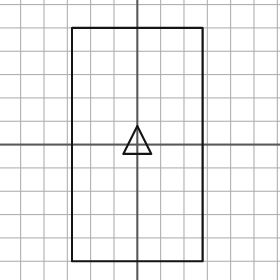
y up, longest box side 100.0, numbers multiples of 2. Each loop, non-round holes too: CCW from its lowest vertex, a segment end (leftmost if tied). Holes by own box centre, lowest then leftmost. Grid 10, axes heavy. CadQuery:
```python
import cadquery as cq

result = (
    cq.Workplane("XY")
    .moveTo(-28.0, -50.0)
    .lineTo(28.0, -50.0)
    .lineTo(28.0, 50.0)
    .lineTo(-28.0, 50.0)
    .close()
    .moveTo(-6.0, -4.0)
    .lineTo(6.0, -4.0)
    .lineTo(0.0, 8.0)
    .close()
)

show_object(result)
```